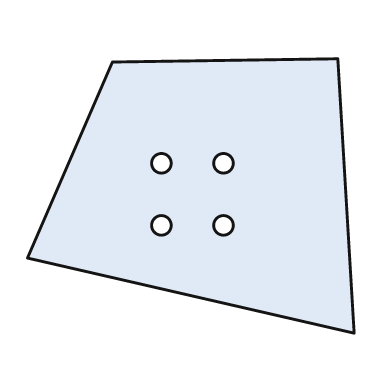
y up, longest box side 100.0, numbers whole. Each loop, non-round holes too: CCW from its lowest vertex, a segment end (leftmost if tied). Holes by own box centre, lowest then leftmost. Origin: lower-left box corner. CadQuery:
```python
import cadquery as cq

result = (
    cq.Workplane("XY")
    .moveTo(100.0, 0.0)
    .lineTo(95.0, 84.0)
    .lineTo(26.0, 83.0)
    .lineTo(0.0, 23.0)
    .close()
    .moveTo(41.0, 33.0)
    .circle(3.0)
    .moveTo(60.0, 33.0)
    .circle(3.0)
    .moveTo(41.0, 52.0)
    .circle(3.0)
    .moveTo(60.0, 52.0)
    .circle(3.0)
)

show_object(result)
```